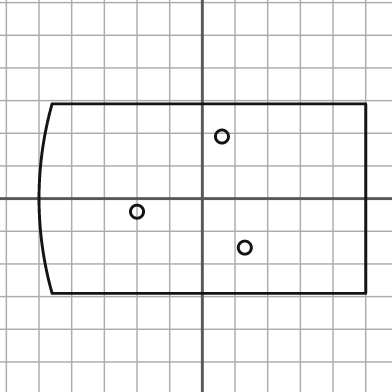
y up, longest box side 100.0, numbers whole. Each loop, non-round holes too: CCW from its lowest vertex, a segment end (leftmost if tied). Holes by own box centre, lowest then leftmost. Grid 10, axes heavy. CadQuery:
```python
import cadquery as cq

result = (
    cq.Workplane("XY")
    .moveTo(-46.0, -29.0)
    .lineTo(50.0, -29.0)
    .lineTo(50.0, 29.0)
    .lineTo(-46.0, 29.0)
    .threePointArc((-50.0, 0.0), (-46.0, -29.0))
    .close()
    .moveTo(13.0, -15.0)
    .circle(2.0)
    .moveTo(-20.0, -4.0)
    .circle(2.0)
    .moveTo(6.0, 19.0)
    .circle(2.0)
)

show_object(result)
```